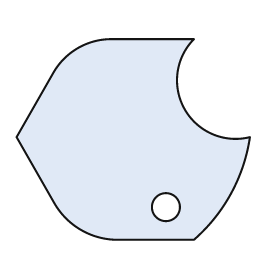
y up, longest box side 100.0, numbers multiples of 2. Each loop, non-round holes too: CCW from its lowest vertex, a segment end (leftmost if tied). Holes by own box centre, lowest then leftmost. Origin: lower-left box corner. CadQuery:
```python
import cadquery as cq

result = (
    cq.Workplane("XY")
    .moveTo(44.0, 0.0)
    .lineTo(76.0, 0.0)
    .threePointArc((92.0, 20.0), (100.0, 44.0))
    .threePointArc((72.0, 56.0), (76.0, 86.0))
    .lineTo(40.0, 86.0)
    .threePointArc((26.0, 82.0), (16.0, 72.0))
    .lineTo(0.0, 44.0)
    .lineTo(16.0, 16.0)
    .threePointArc((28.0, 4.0), (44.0, 0.0))
    .close()
    .moveTo(64.0, 14.0)
    .circle(6.0)
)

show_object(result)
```